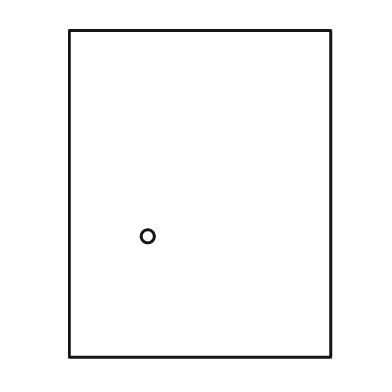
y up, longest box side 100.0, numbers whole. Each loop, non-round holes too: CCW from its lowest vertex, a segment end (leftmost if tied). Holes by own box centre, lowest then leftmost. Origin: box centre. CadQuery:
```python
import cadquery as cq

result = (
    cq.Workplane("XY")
    .moveTo(-40.0, -50.0)
    .lineTo(40.0, -50.0)
    .lineTo(40.0, 50.0)
    .lineTo(-40.0, 50.0)
    .close()
    .moveTo(-16.0, -13.0)
    .circle(2.0)
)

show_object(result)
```